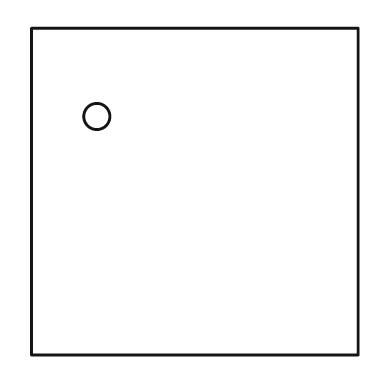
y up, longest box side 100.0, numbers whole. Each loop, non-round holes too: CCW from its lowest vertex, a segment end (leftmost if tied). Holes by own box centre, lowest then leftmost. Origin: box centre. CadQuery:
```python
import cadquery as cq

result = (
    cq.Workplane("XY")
    .moveTo(-50.0, -50.0)
    .lineTo(50.0, -50.0)
    .lineTo(50.0, 50.0)
    .lineTo(-50.0, 50.0)
    .close()
    .moveTo(-30.0, 23.0)
    .circle(4.0)
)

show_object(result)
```